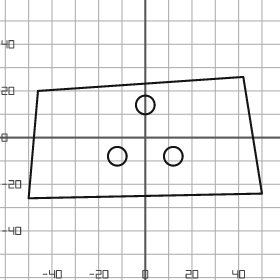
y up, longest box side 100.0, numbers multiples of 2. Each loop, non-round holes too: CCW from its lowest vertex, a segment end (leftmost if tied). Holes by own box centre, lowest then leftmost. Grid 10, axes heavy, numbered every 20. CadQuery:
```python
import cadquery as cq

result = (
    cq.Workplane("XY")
    .moveTo(-50.0, -26.0)
    .lineTo(50.0, -24.0)
    .lineTo(42.0, 26.0)
    .lineTo(-46.0, 20.0)
    .close()
    .moveTo(-12.0, -8.0)
    .circle(4.0)
    .moveTo(12.0, -8.0)
    .circle(4.0)
    .moveTo(0.0, 14.0)
    .circle(4.0)
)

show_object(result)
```